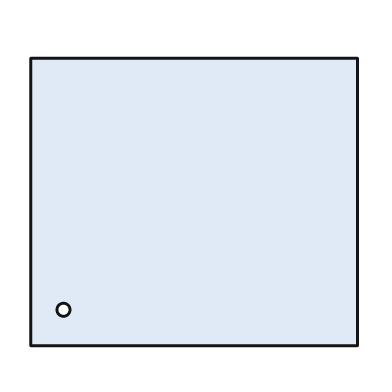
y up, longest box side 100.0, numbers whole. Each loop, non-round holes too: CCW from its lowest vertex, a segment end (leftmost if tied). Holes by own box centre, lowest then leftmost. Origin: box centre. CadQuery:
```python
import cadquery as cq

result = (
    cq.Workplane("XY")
    .moveTo(-50.0, -44.0)
    .lineTo(50.0, -44.0)
    .lineTo(50.0, 44.0)
    .lineTo(-50.0, 44.0)
    .close()
    .moveTo(-40.0, -33.0)
    .circle(2.0)
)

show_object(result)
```